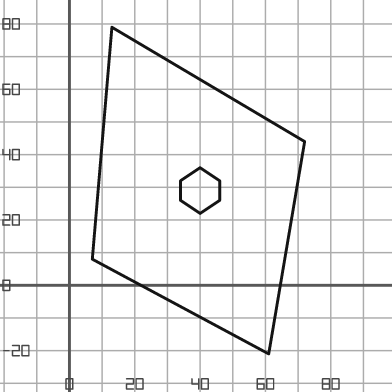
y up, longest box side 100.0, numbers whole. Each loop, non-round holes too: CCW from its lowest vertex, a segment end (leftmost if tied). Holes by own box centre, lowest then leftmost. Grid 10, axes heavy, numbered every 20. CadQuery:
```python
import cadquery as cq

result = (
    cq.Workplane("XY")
    .moveTo(61.0, -21.0)
    .lineTo(72.0, 44.0)
    .lineTo(13.0, 79.0)
    .lineTo(7.0, 8.0)
    .close()
    .moveTo(40.0, 22.0)
    .lineTo(46.0, 26.0)
    .lineTo(46.0, 32.0)
    .lineTo(40.0, 36.0)
    .lineTo(34.0, 32.0)
    .lineTo(34.0, 26.0)
    .close()
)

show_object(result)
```